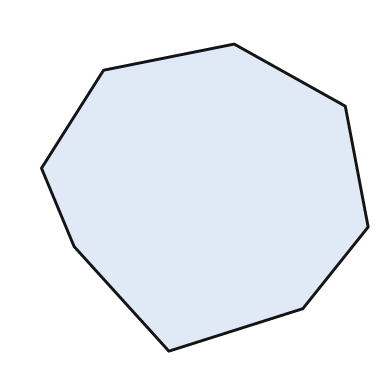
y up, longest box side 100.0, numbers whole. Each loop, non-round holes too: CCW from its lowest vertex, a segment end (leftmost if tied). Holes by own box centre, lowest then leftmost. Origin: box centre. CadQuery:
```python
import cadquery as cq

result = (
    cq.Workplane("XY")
    .moveTo(-11.0, -47.0)
    .lineTo(30.0, -34.0)
    .lineTo(50.0, -9.0)
    .lineTo(43.0, 28.0)
    .lineTo(9.0, 47.0)
    .lineTo(-31.0, 39.0)
    .lineTo(-50.0, 9.0)
    .lineTo(-40.0, -15.0)
    .close()
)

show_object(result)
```